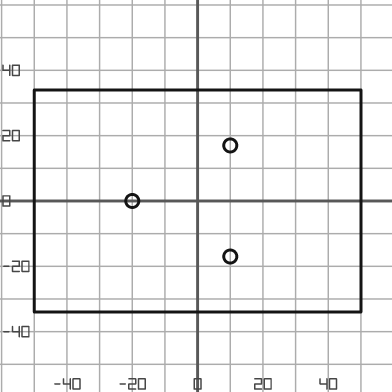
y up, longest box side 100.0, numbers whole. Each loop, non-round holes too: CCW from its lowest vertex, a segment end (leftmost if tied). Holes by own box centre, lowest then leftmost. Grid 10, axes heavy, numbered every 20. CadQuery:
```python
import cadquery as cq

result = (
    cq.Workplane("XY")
    .moveTo(-50.0, -34.0)
    .lineTo(50.0, -34.0)
    .lineTo(50.0, 34.0)
    .lineTo(-50.0, 34.0)
    .close()
    .moveTo(10.0, -17.0)
    .circle(2.0)
    .moveTo(-20.0, 0.0)
    .circle(2.0)
    .moveTo(10.0, 17.0)
    .circle(2.0)
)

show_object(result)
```